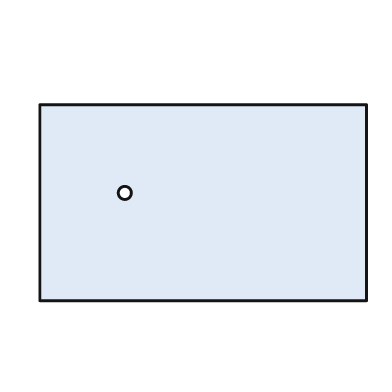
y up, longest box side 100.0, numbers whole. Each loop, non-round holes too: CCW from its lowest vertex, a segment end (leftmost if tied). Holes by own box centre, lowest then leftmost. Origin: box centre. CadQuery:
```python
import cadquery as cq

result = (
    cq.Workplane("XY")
    .moveTo(-50.0, -30.0)
    .lineTo(50.0, -30.0)
    .lineTo(50.0, 30.0)
    .lineTo(-50.0, 30.0)
    .close()
    .moveTo(-24.0, 3.0)
    .circle(2.0)
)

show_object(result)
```